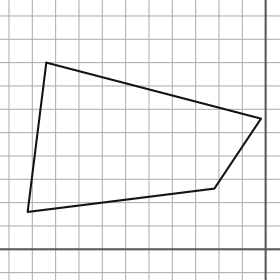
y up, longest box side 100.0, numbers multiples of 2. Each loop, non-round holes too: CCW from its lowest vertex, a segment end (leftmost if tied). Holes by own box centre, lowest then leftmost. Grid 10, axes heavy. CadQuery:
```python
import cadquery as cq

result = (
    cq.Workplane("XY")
    .moveTo(-102.0, 16.0)
    .lineTo(-22.0, 26.0)
    .lineTo(-2.0, 56.0)
    .lineTo(-94.0, 80.0)
    .close()
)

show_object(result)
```